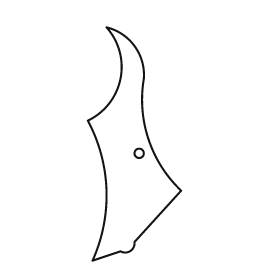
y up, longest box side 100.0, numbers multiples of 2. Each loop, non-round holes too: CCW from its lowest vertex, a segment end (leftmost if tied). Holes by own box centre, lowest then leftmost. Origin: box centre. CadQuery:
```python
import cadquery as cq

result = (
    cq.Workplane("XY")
    .moveTo(-18.0, -50.0)
    .lineTo(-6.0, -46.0)
    .threePointArc((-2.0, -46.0), (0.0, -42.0))
    .lineTo(20.0, -20.0)
    .threePointArc((6.0, 2.0), (4.0, 28.0))
    .threePointArc((0.0, 42.0), (-12.0, 50.0))
    .threePointArc((-6.0, 28.0), (-20.0, 10.0))
    .threePointArc((-12.0, -20.0), (-18.0, -50.0))
    .close()
    .moveTo(2.0, -4.0)
    .circle(2.0)
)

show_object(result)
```